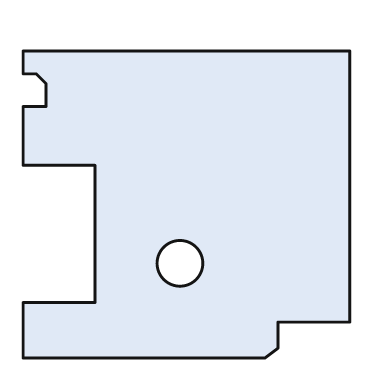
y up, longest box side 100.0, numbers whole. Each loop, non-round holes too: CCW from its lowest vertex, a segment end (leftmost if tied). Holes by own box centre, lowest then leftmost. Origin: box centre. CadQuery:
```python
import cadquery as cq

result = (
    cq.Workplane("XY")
    .moveTo(-50.0, -47.0)
    .lineTo(24.0, -47.0)
    .lineTo(28.0, -44.0)
    .lineTo(28.0, -36.0)
    .lineTo(50.0, -36.0)
    .lineTo(50.0, 47.0)
    .lineTo(-50.0, 47.0)
    .lineTo(-50.0, 40.0)
    .lineTo(-46.0, 40.0)
    .lineTo(-43.0, 37.0)
    .lineTo(-43.0, 30.0)
    .lineTo(-50.0, 30.0)
    .lineTo(-50.0, 12.0)
    .lineTo(-28.0, 12.0)
    .lineTo(-28.0, -30.0)
    .lineTo(-50.0, -30.0)
    .close()
    .moveTo(-2.0, -18.0)
    .circle(7.0)
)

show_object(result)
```